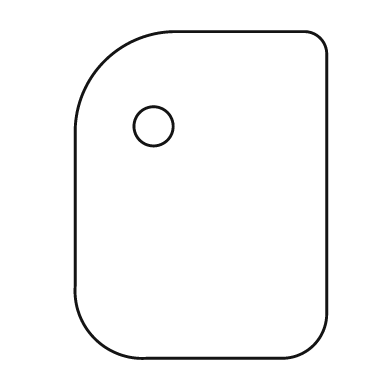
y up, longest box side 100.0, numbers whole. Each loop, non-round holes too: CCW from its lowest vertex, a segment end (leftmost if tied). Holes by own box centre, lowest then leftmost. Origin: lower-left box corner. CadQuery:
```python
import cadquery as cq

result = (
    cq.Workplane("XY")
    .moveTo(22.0, 0.0)
    .lineTo(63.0, 0.0)
    .threePointArc((73.0, 4.0), (77.0, 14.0))
    .lineTo(77.0, 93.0)
    .threePointArc((75.0, 98.0), (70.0, 100.0))
    .lineTo(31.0, 100.0)
    .threePointArc((9.0, 91.0), (0.0, 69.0))
    .lineTo(0.0, 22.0)
    .threePointArc((6.0, 6.0), (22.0, 0.0))
    .close()
    .moveTo(24.0, 71.0)
    .circle(6.0)
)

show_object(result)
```